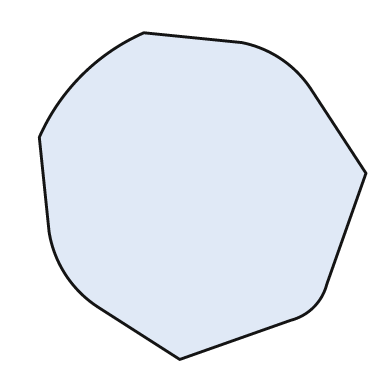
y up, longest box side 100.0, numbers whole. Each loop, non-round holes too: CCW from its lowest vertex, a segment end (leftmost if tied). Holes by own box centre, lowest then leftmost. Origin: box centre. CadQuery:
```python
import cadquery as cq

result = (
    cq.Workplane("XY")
    .moveTo(-7.0, -50.0)
    .lineTo(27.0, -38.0)
    .threePointArc((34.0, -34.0), (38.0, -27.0))
    .lineTo(50.0, 7.0)
    .lineTo(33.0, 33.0)
    .threePointArc((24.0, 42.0), (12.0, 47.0))
    .lineTo(-18.0, 50.0)
    .threePointArc((-37.0, 37.0), (-50.0, 18.0))
    .lineTo(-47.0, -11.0)
    .threePointArc((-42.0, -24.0), (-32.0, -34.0))
    .close()
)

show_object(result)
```